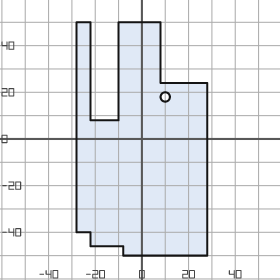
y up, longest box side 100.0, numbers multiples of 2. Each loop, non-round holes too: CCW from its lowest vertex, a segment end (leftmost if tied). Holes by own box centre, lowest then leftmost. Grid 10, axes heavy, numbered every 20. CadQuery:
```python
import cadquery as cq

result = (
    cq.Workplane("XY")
    .moveTo(-8.0, -50.0)
    .lineTo(28.0, -50.0)
    .lineTo(28.0, 24.0)
    .lineTo(8.0, 24.0)
    .lineTo(8.0, 50.0)
    .lineTo(-10.0, 50.0)
    .lineTo(-10.0, 8.0)
    .lineTo(-22.0, 8.0)
    .lineTo(-22.0, 50.0)
    .lineTo(-28.0, 50.0)
    .lineTo(-28.0, -40.0)
    .lineTo(-22.0, -40.0)
    .lineTo(-22.0, -46.0)
    .lineTo(-8.0, -46.0)
    .close()
    .moveTo(10.0, 18.0)
    .circle(2.0)
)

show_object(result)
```